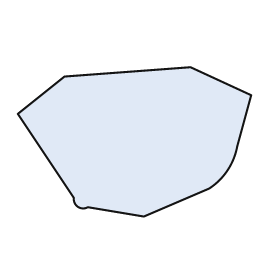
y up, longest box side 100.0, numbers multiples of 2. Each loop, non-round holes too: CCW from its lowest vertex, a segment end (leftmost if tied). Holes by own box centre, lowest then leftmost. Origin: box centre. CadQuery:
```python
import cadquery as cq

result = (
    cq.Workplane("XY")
    .moveTo(4.0, -32.0)
    .lineTo(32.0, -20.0)
    .threePointArc((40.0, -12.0), (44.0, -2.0))
    .lineTo(50.0, 20.0)
    .lineTo(24.0, 32.0)
    .lineTo(-30.0, 28.0)
    .lineTo(-50.0, 12.0)
    .lineTo(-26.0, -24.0)
    .threePointArc((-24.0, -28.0), (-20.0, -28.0))
    .close()
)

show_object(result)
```